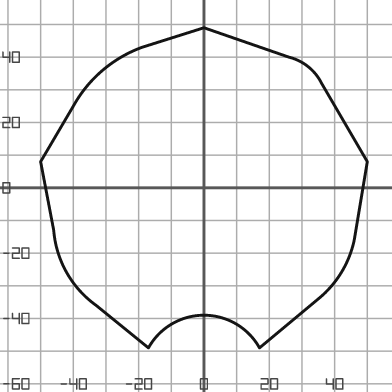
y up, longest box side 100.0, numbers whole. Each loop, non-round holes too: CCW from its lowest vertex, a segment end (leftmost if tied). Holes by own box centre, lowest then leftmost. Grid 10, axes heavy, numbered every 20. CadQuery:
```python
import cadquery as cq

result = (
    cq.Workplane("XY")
    .moveTo(-17.0, -49.0)
    .threePointArc((0.0, -39.0), (17.0, -49.0))
    .lineTo(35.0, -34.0)
    .threePointArc((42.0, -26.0), (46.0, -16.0))
    .lineTo(50.0, 8.0)
    .lineTo(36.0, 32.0)
    .threePointArc((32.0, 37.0), (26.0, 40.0))
    .lineTo(0.0, 49.0)
    .lineTo(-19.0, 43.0)
    .threePointArc((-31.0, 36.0), (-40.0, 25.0))
    .lineTo(-50.0, 8.0)
    .lineTo(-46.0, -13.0)
    .threePointArc((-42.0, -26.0), (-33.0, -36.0))
    .close()
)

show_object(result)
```